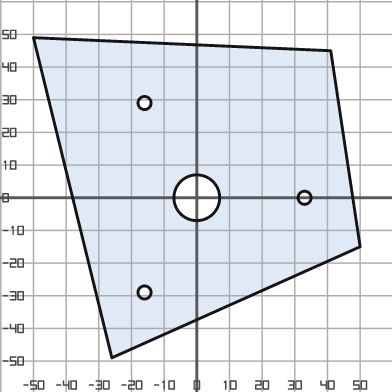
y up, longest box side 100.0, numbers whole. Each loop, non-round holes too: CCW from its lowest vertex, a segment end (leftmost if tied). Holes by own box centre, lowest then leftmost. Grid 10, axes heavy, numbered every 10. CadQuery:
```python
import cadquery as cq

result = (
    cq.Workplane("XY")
    .moveTo(-26.0, -49.0)
    .lineTo(50.0, -15.0)
    .lineTo(41.0, 45.0)
    .lineTo(-50.0, 49.0)
    .close()
    .moveTo(-16.0, -29.0)
    .circle(2.0)
    .moveTo(0.0, 0.0)
    .circle(7.0)
    .moveTo(33.0, 0.0)
    .circle(2.0)
    .moveTo(-16.0, 29.0)
    .circle(2.0)
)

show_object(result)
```